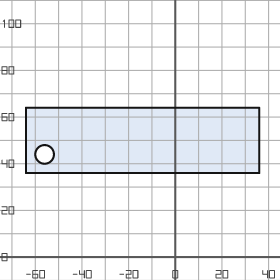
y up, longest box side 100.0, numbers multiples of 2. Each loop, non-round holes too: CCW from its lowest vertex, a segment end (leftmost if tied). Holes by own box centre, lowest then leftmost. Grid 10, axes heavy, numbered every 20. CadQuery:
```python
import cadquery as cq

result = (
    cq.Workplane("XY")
    .moveTo(-64.0, 36.0)
    .lineTo(36.0, 36.0)
    .lineTo(36.0, 64.0)
    .lineTo(-64.0, 64.0)
    .close()
    .moveTo(-56.0, 44.0)
    .circle(4.0)
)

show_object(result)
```